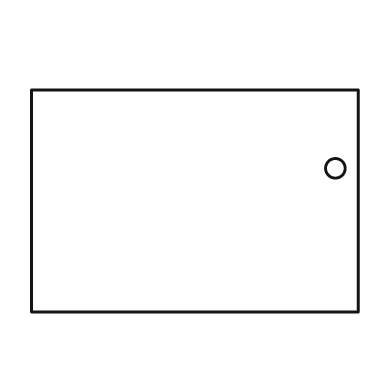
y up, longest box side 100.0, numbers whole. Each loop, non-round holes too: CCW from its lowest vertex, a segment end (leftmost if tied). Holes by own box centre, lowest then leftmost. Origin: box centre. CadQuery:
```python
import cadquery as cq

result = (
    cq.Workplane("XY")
    .moveTo(-50.0, -34.0)
    .lineTo(50.0, -34.0)
    .lineTo(50.0, 34.0)
    .lineTo(-50.0, 34.0)
    .close()
    .moveTo(43.0, 10.0)
    .circle(3.0)
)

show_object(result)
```